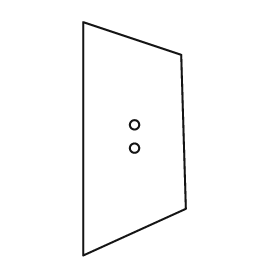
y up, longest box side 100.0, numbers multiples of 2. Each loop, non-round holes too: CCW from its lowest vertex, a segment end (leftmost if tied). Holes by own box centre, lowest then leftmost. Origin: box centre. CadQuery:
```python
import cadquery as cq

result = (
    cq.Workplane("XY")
    .moveTo(-22.0, -50.0)
    .lineTo(22.0, -30.0)
    .lineTo(20.0, 36.0)
    .lineTo(-22.0, 50.0)
    .close()
    .moveTo(0.0, -4.0)
    .circle(2.0)
    .moveTo(0.0, 6.0)
    .circle(2.0)
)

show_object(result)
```